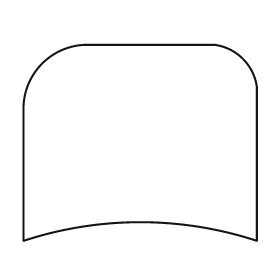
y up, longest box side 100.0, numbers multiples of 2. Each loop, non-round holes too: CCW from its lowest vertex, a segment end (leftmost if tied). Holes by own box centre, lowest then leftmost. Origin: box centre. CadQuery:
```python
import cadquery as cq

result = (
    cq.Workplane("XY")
    .moveTo(-50.0, -42.0)
    .threePointArc((0.0, -34.0), (50.0, -42.0))
    .lineTo(50.0, 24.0)
    .threePointArc((44.0, 36.0), (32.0, 42.0))
    .lineTo(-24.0, 42.0)
    .threePointArc((-42.0, 34.0), (-50.0, 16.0))
    .close()
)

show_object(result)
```